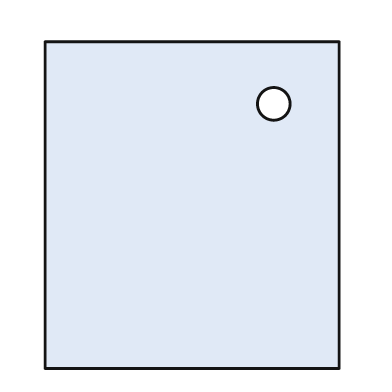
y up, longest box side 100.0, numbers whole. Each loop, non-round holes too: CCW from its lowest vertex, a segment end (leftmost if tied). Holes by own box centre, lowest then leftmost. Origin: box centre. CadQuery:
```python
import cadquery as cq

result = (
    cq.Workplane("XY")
    .moveTo(-45.0, -50.0)
    .lineTo(45.0, -50.0)
    .lineTo(45.0, 50.0)
    .lineTo(-45.0, 50.0)
    .close()
    .moveTo(25.0, 31.0)
    .circle(5.0)
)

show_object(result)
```